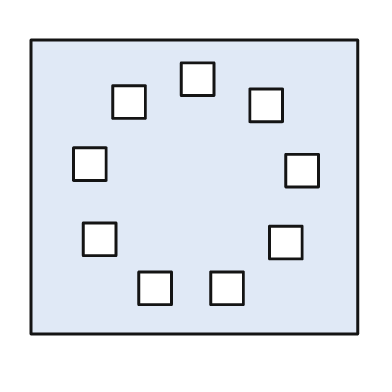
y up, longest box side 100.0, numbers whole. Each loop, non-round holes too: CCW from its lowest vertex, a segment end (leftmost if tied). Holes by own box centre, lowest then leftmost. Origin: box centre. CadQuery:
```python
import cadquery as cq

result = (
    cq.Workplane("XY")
    .moveTo(-50.0, -45.0)
    .lineTo(50.0, -45.0)
    .lineTo(50.0, 45.0)
    .lineTo(-50.0, 45.0)
    .close()
    .moveTo(-17.0, -36.0)
    .lineTo(-7.0, -36.0)
    .lineTo(-7.0, -26.0)
    .lineTo(-17.0, -26.0)
    .close()
    .moveTo(5.0, -36.0)
    .lineTo(15.0, -36.0)
    .lineTo(15.0, -26.0)
    .lineTo(5.0, -26.0)
    .close()
    .moveTo(23.0, -22.0)
    .lineTo(33.0, -22.0)
    .lineTo(33.0, -12.0)
    .lineTo(23.0, -12.0)
    .close()
    .moveTo(-34.0, -21.0)
    .lineTo(-24.0, -21.0)
    .lineTo(-24.0, -11.0)
    .lineTo(-34.0, -11.0)
    .close()
    .moveTo(28.0, 0.0)
    .lineTo(38.0, 0.0)
    .lineTo(38.0, 10.0)
    .lineTo(28.0, 10.0)
    .close()
    .moveTo(-37.0, 2.0)
    .lineTo(-27.0, 2.0)
    .lineTo(-27.0, 12.0)
    .lineTo(-37.0, 12.0)
    .close()
    .moveTo(17.0, 20.0)
    .lineTo(27.0, 20.0)
    .lineTo(27.0, 30.0)
    .lineTo(17.0, 30.0)
    .close()
    .moveTo(-25.0, 21.0)
    .lineTo(-15.0, 21.0)
    .lineTo(-15.0, 31.0)
    .lineTo(-25.0, 31.0)
    .close()
    .moveTo(-4.0, 28.0)
    .lineTo(6.0, 28.0)
    .lineTo(6.0, 38.0)
    .lineTo(-4.0, 38.0)
    .close()
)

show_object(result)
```